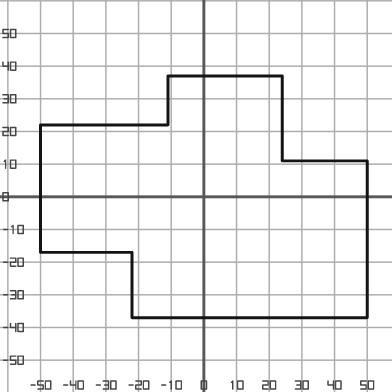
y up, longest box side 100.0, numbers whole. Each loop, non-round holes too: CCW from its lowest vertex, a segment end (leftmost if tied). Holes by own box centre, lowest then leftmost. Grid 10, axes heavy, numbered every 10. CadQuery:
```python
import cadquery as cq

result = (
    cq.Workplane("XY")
    .moveTo(-22.0, -37.0)
    .lineTo(50.0, -37.0)
    .lineTo(50.0, 11.0)
    .lineTo(24.0, 11.0)
    .lineTo(24.0, 37.0)
    .lineTo(-11.0, 37.0)
    .lineTo(-11.0, 22.0)
    .lineTo(-50.0, 22.0)
    .lineTo(-50.0, -17.0)
    .lineTo(-22.0, -17.0)
    .close()
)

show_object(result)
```